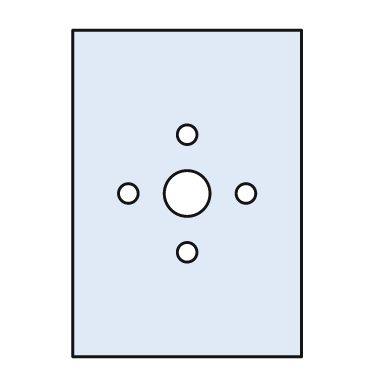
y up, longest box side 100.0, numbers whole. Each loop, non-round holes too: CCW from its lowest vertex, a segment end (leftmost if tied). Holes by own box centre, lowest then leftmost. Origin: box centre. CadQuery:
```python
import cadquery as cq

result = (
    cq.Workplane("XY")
    .moveTo(-35.0, -50.0)
    .lineTo(35.0, -50.0)
    .lineTo(35.0, 50.0)
    .lineTo(-35.0, 50.0)
    .close()
    .moveTo(0.0, -18.0)
    .circle(3.0)
    .moveTo(-18.0, 0.0)
    .circle(3.0)
    .moveTo(0.0, 0.0)
    .circle(7.0)
    .moveTo(18.0, 0.0)
    .circle(3.0)
    .moveTo(0.0, 18.0)
    .circle(3.0)
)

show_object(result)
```